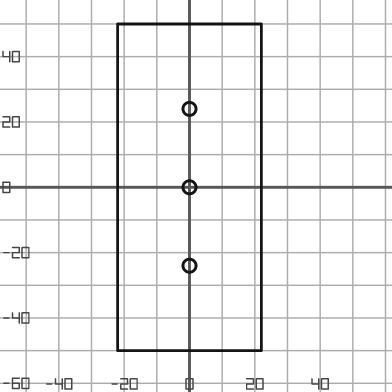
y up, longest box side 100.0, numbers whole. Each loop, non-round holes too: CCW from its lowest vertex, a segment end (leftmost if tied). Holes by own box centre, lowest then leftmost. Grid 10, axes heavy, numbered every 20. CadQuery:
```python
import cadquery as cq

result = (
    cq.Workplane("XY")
    .moveTo(-22.0, -50.0)
    .lineTo(22.0, -50.0)
    .lineTo(22.0, 50.0)
    .lineTo(-22.0, 50.0)
    .close()
    .moveTo(0.0, -24.0)
    .circle(2.0)
    .moveTo(0.0, 0.0)
    .circle(2.0)
    .moveTo(0.0, 24.0)
    .circle(2.0)
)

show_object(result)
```